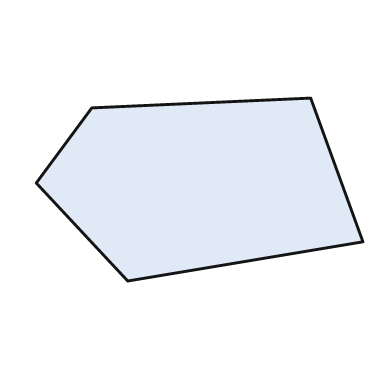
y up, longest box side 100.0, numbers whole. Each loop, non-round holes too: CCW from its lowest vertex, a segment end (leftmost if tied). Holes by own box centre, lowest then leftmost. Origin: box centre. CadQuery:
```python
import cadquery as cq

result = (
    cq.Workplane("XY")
    .moveTo(-22.0, -28.0)
    .lineTo(50.0, -16.0)
    .lineTo(34.0, 28.0)
    .lineTo(-33.0, 25.0)
    .lineTo(-50.0, 2.0)
    .close()
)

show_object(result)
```